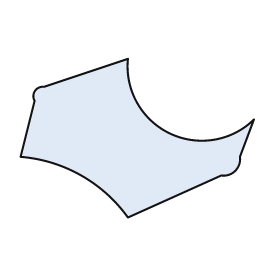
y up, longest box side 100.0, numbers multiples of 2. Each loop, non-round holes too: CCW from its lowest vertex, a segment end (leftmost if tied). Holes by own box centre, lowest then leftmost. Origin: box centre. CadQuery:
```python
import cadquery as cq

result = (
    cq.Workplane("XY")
    .moveTo(-4.0, -34.0)
    .lineTo(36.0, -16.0)
    .threePointArc((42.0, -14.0), (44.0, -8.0))
    .lineTo(50.0, 8.0)
    .threePointArc((14.0, 2.0), (-4.0, 34.0))
    .lineTo(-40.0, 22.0)
    .threePointArc((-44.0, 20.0), (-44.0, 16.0))
    .lineTo(-50.0, -8.0)
    .threePointArc((-24.0, -16.0), (-4.0, -34.0))
    .close()
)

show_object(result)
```